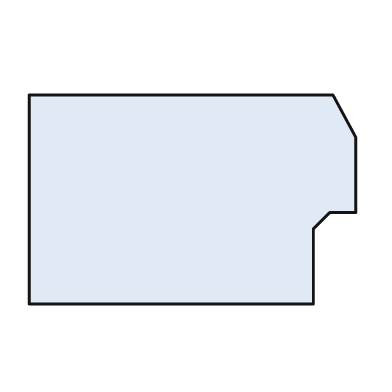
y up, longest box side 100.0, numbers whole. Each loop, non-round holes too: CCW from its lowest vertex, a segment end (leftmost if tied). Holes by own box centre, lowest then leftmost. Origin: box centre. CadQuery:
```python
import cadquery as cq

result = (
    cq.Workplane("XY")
    .moveTo(-50.0, -32.0)
    .lineTo(37.0, -32.0)
    .lineTo(37.0, -9.0)
    .lineTo(42.0, -4.0)
    .lineTo(50.0, -4.0)
    .lineTo(50.0, 19.0)
    .lineTo(43.0, 32.0)
    .lineTo(-50.0, 32.0)
    .close()
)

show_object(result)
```